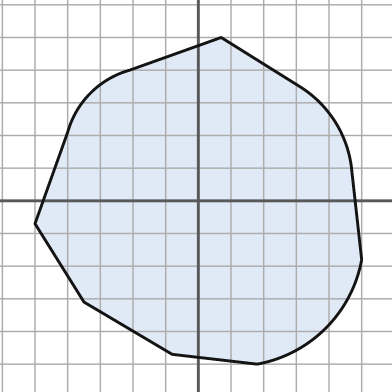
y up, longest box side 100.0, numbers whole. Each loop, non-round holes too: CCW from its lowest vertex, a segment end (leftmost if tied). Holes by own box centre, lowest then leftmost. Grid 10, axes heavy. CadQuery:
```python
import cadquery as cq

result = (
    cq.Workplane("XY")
    .moveTo(18.0, -50.0)
    .threePointArc((39.0, -39.0), (50.0, -18.0))
    .lineTo(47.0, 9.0)
    .threePointArc((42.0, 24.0), (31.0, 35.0))
    .lineTo(7.0, 50.0)
    .lineTo(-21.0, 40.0)
    .threePointArc((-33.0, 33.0), (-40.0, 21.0))
    .lineTo(-50.0, -7.0)
    .lineTo(-35.0, -31.0)
    .lineTo(-8.0, -47.0)
    .close()
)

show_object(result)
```